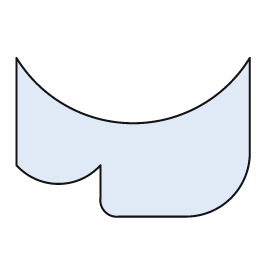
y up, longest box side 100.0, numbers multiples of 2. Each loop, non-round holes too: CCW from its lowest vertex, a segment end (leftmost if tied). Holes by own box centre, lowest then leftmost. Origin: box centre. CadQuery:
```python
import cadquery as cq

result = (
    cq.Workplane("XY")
    .moveTo(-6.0, -34.0)
    .lineTo(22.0, -34.0)
    .threePointArc((42.0, -26.0), (50.0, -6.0))
    .lineTo(50.0, 34.0)
    .threePointArc((0.0, 6.0), (-50.0, 34.0))
    .lineTo(-50.0, -12.0)
    .threePointArc((-32.0, -20.0), (-14.0, -12.0))
    .lineTo(-14.0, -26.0)
    .threePointArc((-12.0, -32.0), (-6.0, -34.0))
    .close()
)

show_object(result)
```